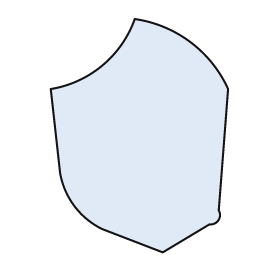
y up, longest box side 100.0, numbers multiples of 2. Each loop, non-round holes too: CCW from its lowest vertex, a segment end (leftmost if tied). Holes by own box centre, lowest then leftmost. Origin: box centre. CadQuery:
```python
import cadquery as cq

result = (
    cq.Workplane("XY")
    .moveTo(10.0, -50.0)
    .lineTo(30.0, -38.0)
    .threePointArc((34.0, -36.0), (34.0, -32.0))
    .lineTo(38.0, 20.0)
    .threePointArc((22.0, 40.0), (-2.0, 50.0))
    .threePointArc((-16.0, 30.0), (-38.0, 20.0))
    .lineTo(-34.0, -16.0)
    .threePointArc((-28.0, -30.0), (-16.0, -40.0))
    .close()
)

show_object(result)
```